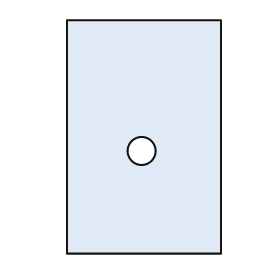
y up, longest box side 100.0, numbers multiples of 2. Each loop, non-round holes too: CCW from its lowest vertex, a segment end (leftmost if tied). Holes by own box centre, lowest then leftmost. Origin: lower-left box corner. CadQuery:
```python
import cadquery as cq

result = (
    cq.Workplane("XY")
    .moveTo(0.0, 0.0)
    .lineTo(66.0, 0.0)
    .lineTo(66.0, 100.0)
    .lineTo(0.0, 100.0)
    .close()
    .moveTo(32.0, 44.0)
    .circle(6.0)
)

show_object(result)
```